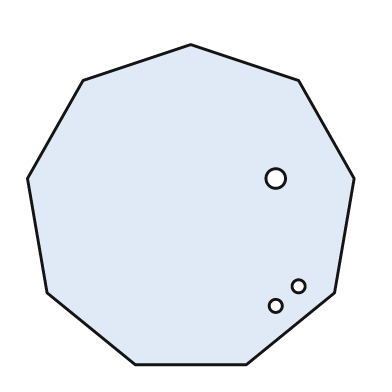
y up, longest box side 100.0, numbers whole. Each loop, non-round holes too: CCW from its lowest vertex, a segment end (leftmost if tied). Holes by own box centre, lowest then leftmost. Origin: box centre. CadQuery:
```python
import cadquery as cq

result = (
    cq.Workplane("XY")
    .moveTo(-17.0, -49.0)
    .lineTo(17.0, -49.0)
    .lineTo(44.0, -27.0)
    .lineTo(50.0, 8.0)
    .lineTo(33.0, 38.0)
    .lineTo(0.0, 49.0)
    .lineTo(-33.0, 38.0)
    .lineTo(-50.0, 8.0)
    .lineTo(-44.0, -27.0)
    .close()
    .moveTo(26.0, -31.0)
    .circle(2.0)
    .moveTo(33.0, -25.0)
    .circle(2.0)
    .moveTo(26.0, 8.0)
    .circle(3.0)
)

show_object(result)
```